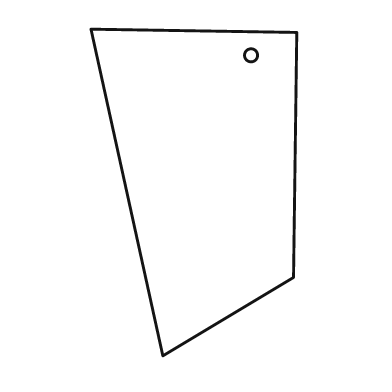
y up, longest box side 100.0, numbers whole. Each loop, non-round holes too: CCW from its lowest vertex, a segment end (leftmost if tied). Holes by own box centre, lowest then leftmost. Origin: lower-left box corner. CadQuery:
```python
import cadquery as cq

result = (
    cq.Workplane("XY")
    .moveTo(22.0, 0.0)
    .lineTo(62.0, 24.0)
    .lineTo(63.0, 99.0)
    .lineTo(0.0, 100.0)
    .close()
    .moveTo(49.0, 92.0)
    .circle(2.0)
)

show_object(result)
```